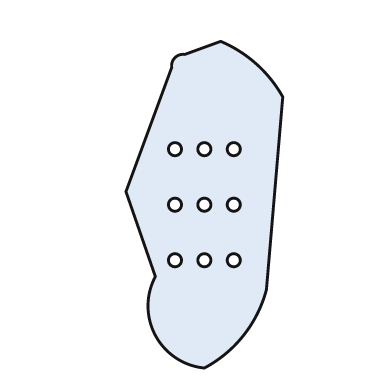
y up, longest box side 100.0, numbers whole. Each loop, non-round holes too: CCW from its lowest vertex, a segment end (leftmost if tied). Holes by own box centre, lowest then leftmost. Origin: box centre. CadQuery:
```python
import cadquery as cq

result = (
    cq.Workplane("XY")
    .moveTo(0.0, -50.0)
    .threePointArc((12.0, -40.0), (19.0, -26.0))
    .lineTo(24.0, 33.0)
    .threePointArc((16.0, 43.0), (5.0, 50.0))
    .lineTo(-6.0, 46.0)
    .threePointArc((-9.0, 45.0), (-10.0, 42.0))
    .lineTo(-24.0, 4.0)
    .lineTo(-15.0, -22.0)
    .threePointArc((-15.0, -40.0), (0.0, -50.0))
    .close()
    .moveTo(-9.0, -17.0)
    .circle(2.0)
    .moveTo(0.0, -17.0)
    .circle(2.0)
    .moveTo(9.0, -17.0)
    .circle(2.0)
    .moveTo(-9.0, 0.0)
    .circle(2.0)
    .moveTo(0.0, 0.0)
    .circle(2.0)
    .moveTo(9.0, 0.0)
    .circle(2.0)
    .moveTo(-9.0, 17.0)
    .circle(2.0)
    .moveTo(0.0, 17.0)
    .circle(2.0)
    .moveTo(9.0, 17.0)
    .circle(2.0)
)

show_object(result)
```